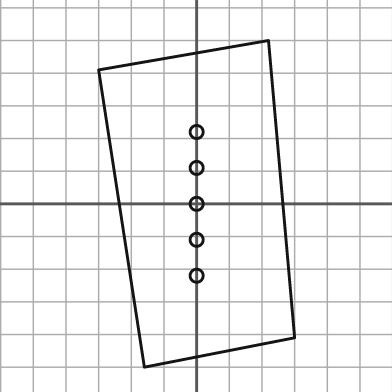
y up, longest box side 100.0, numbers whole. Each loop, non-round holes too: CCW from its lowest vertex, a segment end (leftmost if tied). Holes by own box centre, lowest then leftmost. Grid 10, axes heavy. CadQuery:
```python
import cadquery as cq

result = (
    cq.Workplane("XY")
    .moveTo(-16.0, -50.0)
    .lineTo(30.0, -41.0)
    .lineTo(22.0, 50.0)
    .lineTo(-30.0, 41.0)
    .close()
    .moveTo(0.0, -22.0)
    .circle(2.0)
    .moveTo(0.0, -11.0)
    .circle(2.0)
    .moveTo(0.0, 0.0)
    .circle(2.0)
    .moveTo(0.0, 11.0)
    .circle(2.0)
    .moveTo(0.0, 22.0)
    .circle(2.0)
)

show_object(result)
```